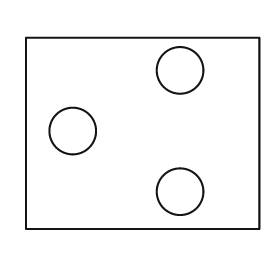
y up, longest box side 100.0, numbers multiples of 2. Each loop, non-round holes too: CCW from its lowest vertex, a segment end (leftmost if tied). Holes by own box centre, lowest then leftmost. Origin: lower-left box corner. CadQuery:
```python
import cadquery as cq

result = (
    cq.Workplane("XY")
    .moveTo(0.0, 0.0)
    .lineTo(100.0, 0.0)
    .lineTo(100.0, 82.0)
    .lineTo(0.0, 82.0)
    .close()
    .moveTo(66.0, 16.0)
    .circle(10.0)
    .moveTo(20.0, 42.0)
    .circle(10.0)
    .moveTo(66.0, 68.0)
    .circle(10.0)
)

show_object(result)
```